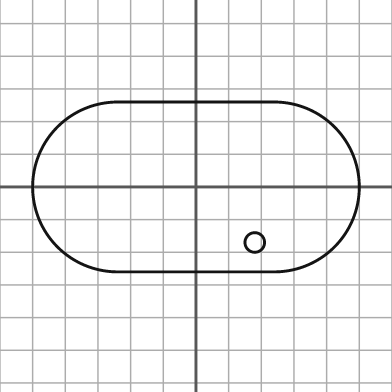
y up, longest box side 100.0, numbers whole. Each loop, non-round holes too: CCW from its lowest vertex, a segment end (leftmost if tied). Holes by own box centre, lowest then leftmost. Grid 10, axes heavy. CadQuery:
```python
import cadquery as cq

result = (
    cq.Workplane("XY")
    .moveTo(-24.0, -26.0)
    .lineTo(24.0, -26.0)
    .threePointArc((50.0, 0.0), (24.0, 26.0))
    .lineTo(-24.0, 26.0)
    .threePointArc((-50.0, 0.0), (-24.0, -26.0))
    .close()
    .moveTo(18.0, -17.0)
    .circle(3.0)
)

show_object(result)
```